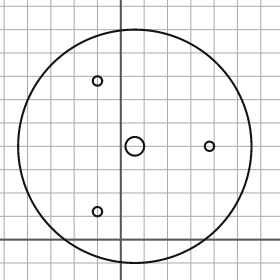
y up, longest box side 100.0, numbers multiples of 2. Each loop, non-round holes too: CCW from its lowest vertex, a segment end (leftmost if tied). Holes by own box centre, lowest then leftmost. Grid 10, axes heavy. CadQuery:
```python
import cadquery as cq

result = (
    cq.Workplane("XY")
    .moveTo(6.0, 40.0)
    .circle(50.0)
    .moveTo(-10.0, 12.0)
    .circle(2.0)
    .moveTo(6.0, 40.0)
    .circle(4.0)
    .moveTo(38.0, 40.0)
    .circle(2.0)
    .moveTo(-10.0, 68.0)
    .circle(2.0)
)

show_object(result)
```